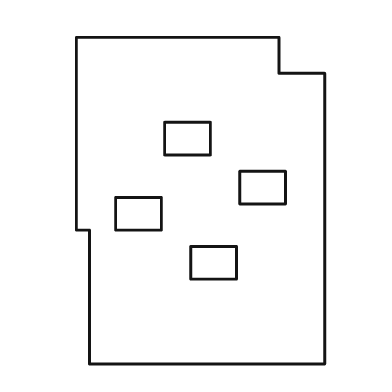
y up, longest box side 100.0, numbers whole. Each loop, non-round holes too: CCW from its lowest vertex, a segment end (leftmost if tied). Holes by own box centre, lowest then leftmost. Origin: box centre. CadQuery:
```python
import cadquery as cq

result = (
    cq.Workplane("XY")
    .moveTo(-34.0, -50.0)
    .lineTo(38.0, -50.0)
    .lineTo(38.0, 39.0)
    .lineTo(24.0, 39.0)
    .lineTo(24.0, 50.0)
    .lineTo(-38.0, 50.0)
    .lineTo(-38.0, -9.0)
    .lineTo(-34.0, -9.0)
    .close()
    .moveTo(-3.0, -24.0)
    .lineTo(11.0, -24.0)
    .lineTo(11.0, -14.0)
    .lineTo(-3.0, -14.0)
    .close()
    .moveTo(-26.0, -9.0)
    .lineTo(-12.0, -9.0)
    .lineTo(-12.0, 1.0)
    .lineTo(-26.0, 1.0)
    .close()
    .moveTo(12.0, -1.0)
    .lineTo(26.0, -1.0)
    .lineTo(26.0, 9.0)
    .lineTo(12.0, 9.0)
    .close()
    .moveTo(-11.0, 14.0)
    .lineTo(3.0, 14.0)
    .lineTo(3.0, 24.0)
    .lineTo(-11.0, 24.0)
    .close()
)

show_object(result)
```